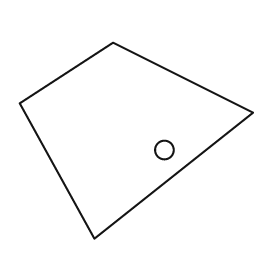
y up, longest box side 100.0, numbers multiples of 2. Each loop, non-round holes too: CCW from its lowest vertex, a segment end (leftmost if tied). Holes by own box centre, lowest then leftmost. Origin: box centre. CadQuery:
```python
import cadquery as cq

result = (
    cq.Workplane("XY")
    .moveTo(-18.0, -42.0)
    .lineTo(50.0, 12.0)
    .lineTo(-10.0, 42.0)
    .lineTo(-50.0, 16.0)
    .close()
    .moveTo(12.0, -4.0)
    .circle(4.0)
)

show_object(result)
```